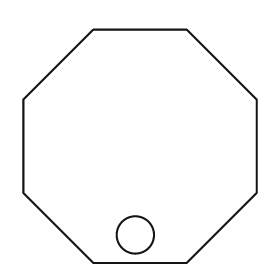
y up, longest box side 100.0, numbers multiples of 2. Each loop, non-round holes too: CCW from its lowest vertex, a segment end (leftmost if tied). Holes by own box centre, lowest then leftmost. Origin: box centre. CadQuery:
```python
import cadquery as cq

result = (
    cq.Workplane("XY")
    .moveTo(-20.0, -50.0)
    .lineTo(20.0, -50.0)
    .lineTo(50.0, -20.0)
    .lineTo(50.0, 20.0)
    .lineTo(20.0, 50.0)
    .lineTo(-20.0, 50.0)
    .lineTo(-50.0, 20.0)
    .lineTo(-50.0, -20.0)
    .close()
    .moveTo(-2.0, -38.0)
    .circle(8.0)
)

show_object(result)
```